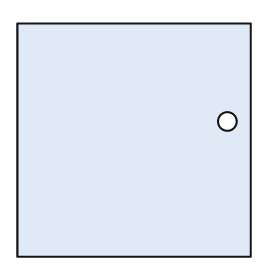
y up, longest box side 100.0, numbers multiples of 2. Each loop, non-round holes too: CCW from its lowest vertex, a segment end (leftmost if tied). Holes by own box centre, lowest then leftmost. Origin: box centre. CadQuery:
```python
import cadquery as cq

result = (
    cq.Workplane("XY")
    .moveTo(-50.0, -50.0)
    .lineTo(50.0, -50.0)
    .lineTo(50.0, 50.0)
    .lineTo(-50.0, 50.0)
    .close()
    .moveTo(40.0, 8.0)
    .circle(4.0)
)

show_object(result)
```